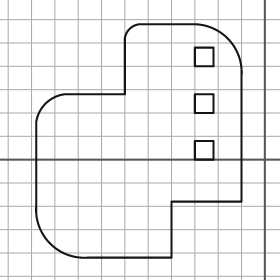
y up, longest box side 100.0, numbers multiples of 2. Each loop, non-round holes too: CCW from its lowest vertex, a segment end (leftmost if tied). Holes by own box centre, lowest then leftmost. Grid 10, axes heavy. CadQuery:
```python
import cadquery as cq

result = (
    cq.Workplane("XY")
    .moveTo(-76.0, -42.0)
    .lineTo(-40.0, -42.0)
    .lineTo(-40.0, -18.0)
    .lineTo(-10.0, -18.0)
    .lineTo(-10.0, 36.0)
    .threePointArc((-16.0, 52.0), (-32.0, 58.0))
    .lineTo(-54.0, 58.0)
    .threePointArc((-58.0, 56.0), (-60.0, 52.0))
    .lineTo(-60.0, 28.0)
    .lineTo(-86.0, 28.0)
    .threePointArc((-94.0, 24.0), (-98.0, 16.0))
    .lineTo(-98.0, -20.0)
    .threePointArc((-92.0, -36.0), (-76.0, -42.0))
    .close()
    .moveTo(-30.0, 0.0)
    .lineTo(-22.0, 0.0)
    .lineTo(-22.0, 8.0)
    .lineTo(-30.0, 8.0)
    .close()
    .moveTo(-30.0, 20.0)
    .lineTo(-22.0, 20.0)
    .lineTo(-22.0, 28.0)
    .lineTo(-30.0, 28.0)
    .close()
    .moveTo(-30.0, 40.0)
    .lineTo(-22.0, 40.0)
    .lineTo(-22.0, 48.0)
    .lineTo(-30.0, 48.0)
    .close()
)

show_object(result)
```